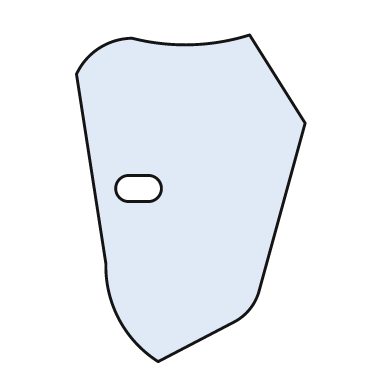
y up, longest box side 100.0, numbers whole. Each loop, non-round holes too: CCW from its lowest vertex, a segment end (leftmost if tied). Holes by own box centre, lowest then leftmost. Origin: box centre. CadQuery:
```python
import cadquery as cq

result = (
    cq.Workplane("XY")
    .moveTo(-10.0, -50.0)
    .lineTo(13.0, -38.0)
    .threePointArc((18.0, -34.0), (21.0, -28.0))
    .lineTo(35.0, 23.0)
    .lineTo(18.0, 50.0)
    .threePointArc((0.0, 47.0), (-18.0, 49.0))
    .threePointArc((-28.0, 46.0), (-35.0, 38.0))
    .lineTo(-26.0, -20.0)
    .threePointArc((-22.0, -37.0), (-10.0, -50.0))
    .close()
    .moveTo(-19.0, -1.0)
    .lineTo(-13.0, -1.0)
    .threePointArc((-9.0, 3.0), (-13.0, 7.0))
    .lineTo(-19.0, 7.0)
    .threePointArc((-23.0, 3.0), (-19.0, -1.0))
    .close()
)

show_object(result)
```